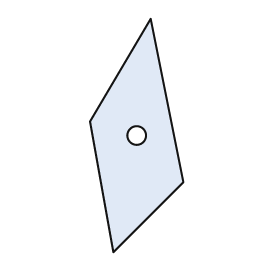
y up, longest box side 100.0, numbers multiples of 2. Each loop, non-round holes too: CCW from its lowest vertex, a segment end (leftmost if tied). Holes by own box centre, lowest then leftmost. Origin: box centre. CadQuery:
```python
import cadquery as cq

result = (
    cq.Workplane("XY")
    .moveTo(-10.0, -50.0)
    .lineTo(20.0, -20.0)
    .lineTo(6.0, 50.0)
    .lineTo(-20.0, 6.0)
    .close()
    .moveTo(0.0, 0.0)
    .circle(4.0)
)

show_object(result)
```